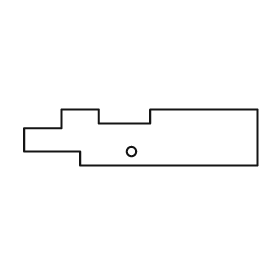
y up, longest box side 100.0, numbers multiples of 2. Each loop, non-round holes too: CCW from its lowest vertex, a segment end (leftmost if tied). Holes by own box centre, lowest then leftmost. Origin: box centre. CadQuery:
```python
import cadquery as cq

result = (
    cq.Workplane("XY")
    .moveTo(-26.0, -12.0)
    .lineTo(50.0, -12.0)
    .lineTo(50.0, 12.0)
    .lineTo(4.0, 12.0)
    .lineTo(4.0, 6.0)
    .lineTo(-18.0, 6.0)
    .lineTo(-18.0, 12.0)
    .lineTo(-34.0, 12.0)
    .lineTo(-34.0, 4.0)
    .lineTo(-50.0, 4.0)
    .lineTo(-50.0, -6.0)
    .lineTo(-26.0, -6.0)
    .close()
    .moveTo(-4.0, -6.0)
    .circle(2.0)
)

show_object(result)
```